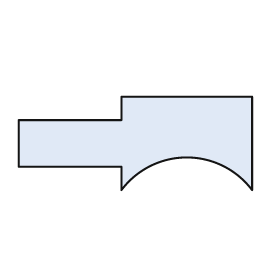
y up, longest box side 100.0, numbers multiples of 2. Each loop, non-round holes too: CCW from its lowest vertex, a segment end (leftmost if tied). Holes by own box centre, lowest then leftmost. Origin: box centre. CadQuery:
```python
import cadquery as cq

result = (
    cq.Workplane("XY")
    .moveTo(-6.0, -20.0)
    .threePointArc((22.0, -6.0), (50.0, -20.0))
    .lineTo(50.0, 20.0)
    .lineTo(-6.0, 20.0)
    .lineTo(-6.0, 10.0)
    .lineTo(-50.0, 10.0)
    .lineTo(-50.0, -10.0)
    .lineTo(-6.0, -10.0)
    .close()
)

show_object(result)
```